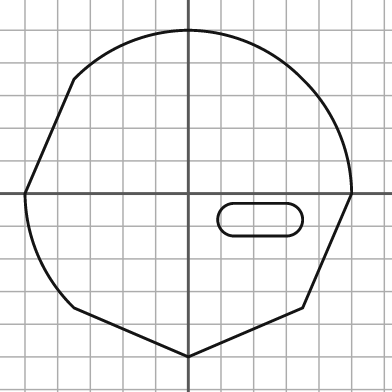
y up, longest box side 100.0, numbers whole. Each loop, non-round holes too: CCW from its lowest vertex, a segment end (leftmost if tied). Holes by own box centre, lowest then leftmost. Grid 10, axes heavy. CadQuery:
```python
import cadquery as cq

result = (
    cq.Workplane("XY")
    .moveTo(0.0, -50.0)
    .lineTo(35.0, -35.0)
    .lineTo(50.0, 0.0)
    .threePointArc((46.0, 19.0), (35.0, 35.0))
    .threePointArc((19.0, 46.0), (0.0, 50.0))
    .threePointArc((-19.0, 46.0), (-35.0, 35.0))
    .lineTo(-50.0, 0.0)
    .threePointArc((-46.0, -19.0), (-35.0, -35.0))
    .close()
    .moveTo(14.0, -13.0)
    .lineTo(30.0, -13.0)
    .threePointArc((35.0, -8.0), (30.0, -3.0))
    .lineTo(14.0, -3.0)
    .threePointArc((9.0, -8.0), (14.0, -13.0))
    .close()
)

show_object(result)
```